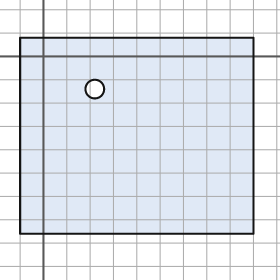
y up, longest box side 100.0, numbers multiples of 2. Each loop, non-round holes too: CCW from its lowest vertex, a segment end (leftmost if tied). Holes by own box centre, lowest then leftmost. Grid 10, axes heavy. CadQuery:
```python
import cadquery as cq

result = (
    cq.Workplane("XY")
    .moveTo(-10.0, -76.0)
    .lineTo(90.0, -76.0)
    .lineTo(90.0, 8.0)
    .lineTo(-10.0, 8.0)
    .close()
    .moveTo(22.0, -14.0)
    .circle(4.0)
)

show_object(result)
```